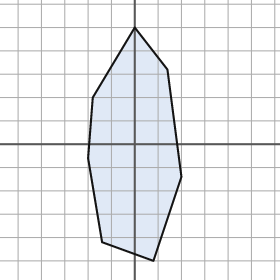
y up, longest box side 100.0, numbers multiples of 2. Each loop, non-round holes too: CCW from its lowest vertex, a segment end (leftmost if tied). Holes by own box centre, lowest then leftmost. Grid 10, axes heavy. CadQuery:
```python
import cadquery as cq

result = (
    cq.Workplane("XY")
    .moveTo(8.0, -50.0)
    .lineTo(20.0, -14.0)
    .lineTo(14.0, 32.0)
    .lineTo(0.0, 50.0)
    .lineTo(-18.0, 20.0)
    .lineTo(-20.0, -6.0)
    .lineTo(-14.0, -42.0)
    .close()
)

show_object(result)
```